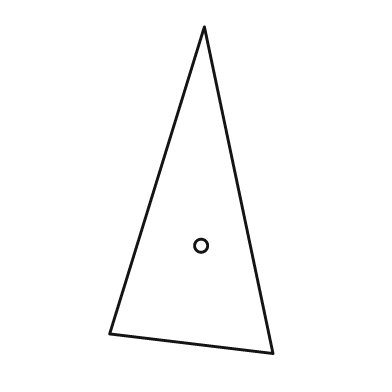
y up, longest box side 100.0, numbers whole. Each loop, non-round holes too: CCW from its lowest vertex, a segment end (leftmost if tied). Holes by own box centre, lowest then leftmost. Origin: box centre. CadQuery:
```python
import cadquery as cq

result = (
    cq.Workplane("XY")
    .moveTo(25.0, -50.0)
    .lineTo(4.0, 50.0)
    .lineTo(-25.0, -44.0)
    .close()
    .moveTo(3.0, -17.0)
    .circle(2.0)
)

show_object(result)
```